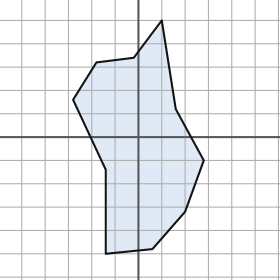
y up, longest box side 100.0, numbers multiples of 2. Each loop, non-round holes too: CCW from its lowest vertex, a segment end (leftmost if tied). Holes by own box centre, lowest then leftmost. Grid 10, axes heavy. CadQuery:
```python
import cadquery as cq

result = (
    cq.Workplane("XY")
    .moveTo(-14.0, -50.0)
    .lineTo(6.0, -48.0)
    .lineTo(20.0, -32.0)
    .lineTo(28.0, -10.0)
    .lineTo(16.0, 12.0)
    .lineTo(10.0, 50.0)
    .lineTo(-2.0, 34.0)
    .lineTo(-18.0, 32.0)
    .lineTo(-28.0, 16.0)
    .lineTo(-14.0, -14.0)
    .close()
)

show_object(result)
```